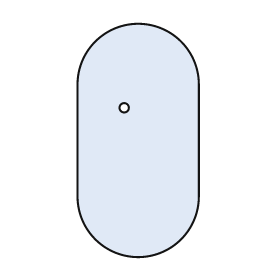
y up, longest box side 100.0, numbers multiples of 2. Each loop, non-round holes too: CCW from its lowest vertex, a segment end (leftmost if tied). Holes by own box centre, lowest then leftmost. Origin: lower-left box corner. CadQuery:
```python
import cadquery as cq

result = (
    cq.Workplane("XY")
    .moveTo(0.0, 26.0)
    .threePointArc((26.0, 0.0), (52.0, 26.0))
    .lineTo(52.0, 74.0)
    .threePointArc((26.0, 100.0), (0.0, 74.0))
    .close()
    .moveTo(20.0, 64.0)
    .circle(2.0)
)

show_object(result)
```